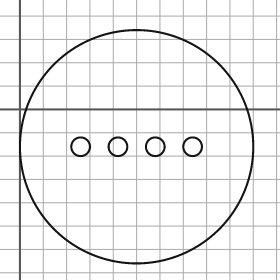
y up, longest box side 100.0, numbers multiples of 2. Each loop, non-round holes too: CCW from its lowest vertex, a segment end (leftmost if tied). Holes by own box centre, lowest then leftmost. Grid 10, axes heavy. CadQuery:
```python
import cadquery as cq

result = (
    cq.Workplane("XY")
    .moveTo(50.0, -16.0)
    .circle(50.0)
    .moveTo(26.0, -16.0)
    .circle(4.0)
    .moveTo(42.0, -16.0)
    .circle(4.0)
    .moveTo(58.0, -16.0)
    .circle(4.0)
    .moveTo(74.0, -16.0)
    .circle(4.0)
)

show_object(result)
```